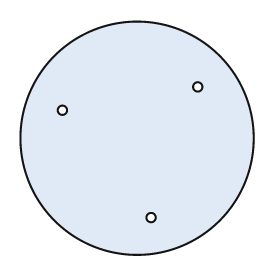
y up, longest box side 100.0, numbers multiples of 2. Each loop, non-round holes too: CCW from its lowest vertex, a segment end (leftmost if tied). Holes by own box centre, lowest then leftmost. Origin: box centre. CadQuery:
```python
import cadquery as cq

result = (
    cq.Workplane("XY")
    .moveTo(0.0, 0.0)
    .circle(50.0)
    .moveTo(6.0, -34.0)
    .circle(2.0)
    .moveTo(-32.0, 12.0)
    .circle(2.0)
    .moveTo(26.0, 22.0)
    .circle(2.0)
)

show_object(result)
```